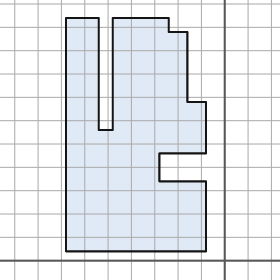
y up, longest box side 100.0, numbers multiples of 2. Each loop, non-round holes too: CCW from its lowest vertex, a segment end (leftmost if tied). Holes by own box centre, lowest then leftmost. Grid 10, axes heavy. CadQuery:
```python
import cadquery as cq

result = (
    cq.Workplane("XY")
    .moveTo(-68.0, 4.0)
    .lineTo(-8.0, 4.0)
    .lineTo(-8.0, 34.0)
    .lineTo(-28.0, 34.0)
    .lineTo(-28.0, 46.0)
    .lineTo(-8.0, 46.0)
    .lineTo(-8.0, 68.0)
    .lineTo(-16.0, 68.0)
    .lineTo(-16.0, 98.0)
    .lineTo(-24.0, 98.0)
    .lineTo(-24.0, 104.0)
    .lineTo(-48.0, 104.0)
    .lineTo(-48.0, 56.0)
    .lineTo(-54.0, 56.0)
    .lineTo(-54.0, 104.0)
    .lineTo(-68.0, 104.0)
    .close()
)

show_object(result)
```